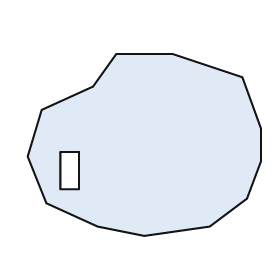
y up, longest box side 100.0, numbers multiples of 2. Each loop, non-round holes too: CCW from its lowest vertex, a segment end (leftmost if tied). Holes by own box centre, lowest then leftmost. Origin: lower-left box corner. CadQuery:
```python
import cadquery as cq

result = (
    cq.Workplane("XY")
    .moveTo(50.0, 0.0)
    .lineTo(78.0, 4.0)
    .lineTo(94.0, 16.0)
    .lineTo(100.0, 32.0)
    .lineTo(100.0, 46.0)
    .lineTo(92.0, 68.0)
    .lineTo(62.0, 78.0)
    .lineTo(38.0, 78.0)
    .lineTo(28.0, 64.0)
    .lineTo(6.0, 54.0)
    .lineTo(0.0, 34.0)
    .lineTo(8.0, 14.0)
    .lineTo(30.0, 4.0)
    .close()
    .moveTo(14.0, 20.0)
    .lineTo(22.0, 20.0)
    .lineTo(22.0, 36.0)
    .lineTo(14.0, 36.0)
    .close()
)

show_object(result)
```